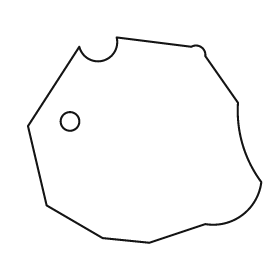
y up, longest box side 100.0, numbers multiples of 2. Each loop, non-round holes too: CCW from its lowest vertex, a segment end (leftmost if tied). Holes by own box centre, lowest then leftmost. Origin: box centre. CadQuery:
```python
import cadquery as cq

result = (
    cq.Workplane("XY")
    .moveTo(2.0, -44.0)
    .lineTo(26.0, -36.0)
    .threePointArc((42.0, -32.0), (50.0, -18.0))
    .threePointArc((42.0, -2.0), (40.0, 16.0))
    .lineTo(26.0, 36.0)
    .threePointArc((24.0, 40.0), (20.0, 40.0))
    .lineTo(-12.0, 44.0)
    .threePointArc((-18.0, 34.0), (-28.0, 40.0))
    .lineTo(-50.0, 6.0)
    .lineTo(-42.0, -28.0)
    .lineTo(-18.0, -42.0)
    .close()
    .moveTo(-32.0, 8.0)
    .circle(4.0)
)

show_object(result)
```